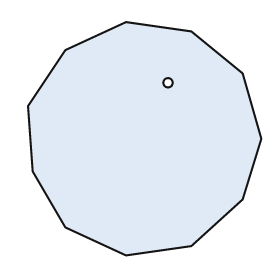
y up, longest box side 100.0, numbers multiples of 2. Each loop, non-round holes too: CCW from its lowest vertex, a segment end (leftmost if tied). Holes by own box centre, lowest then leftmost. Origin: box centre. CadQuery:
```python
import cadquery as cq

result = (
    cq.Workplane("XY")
    .moveTo(-8.0, -50.0)
    .lineTo(20.0, -46.0)
    .lineTo(42.0, -26.0)
    .lineTo(50.0, 0.0)
    .lineTo(42.0, 28.0)
    .lineTo(20.0, 46.0)
    .lineTo(-8.0, 50.0)
    .lineTo(-34.0, 38.0)
    .lineTo(-50.0, 14.0)
    .lineTo(-48.0, -14.0)
    .lineTo(-34.0, -38.0)
    .close()
    .moveTo(10.0, 24.0)
    .circle(2.0)
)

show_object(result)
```